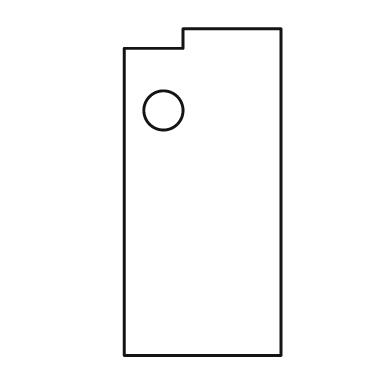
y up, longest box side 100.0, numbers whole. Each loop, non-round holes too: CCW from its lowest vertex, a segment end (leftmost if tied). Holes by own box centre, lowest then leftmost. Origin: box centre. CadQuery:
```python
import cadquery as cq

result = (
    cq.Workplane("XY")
    .moveTo(-24.0, -50.0)
    .lineTo(24.0, -50.0)
    .lineTo(24.0, 50.0)
    .lineTo(-6.0, 50.0)
    .lineTo(-6.0, 44.0)
    .lineTo(-24.0, 44.0)
    .close()
    .moveTo(-12.0, 25.0)
    .circle(6.0)
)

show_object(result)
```